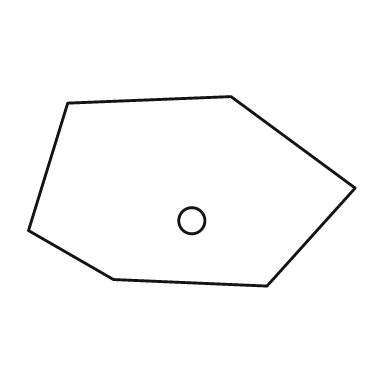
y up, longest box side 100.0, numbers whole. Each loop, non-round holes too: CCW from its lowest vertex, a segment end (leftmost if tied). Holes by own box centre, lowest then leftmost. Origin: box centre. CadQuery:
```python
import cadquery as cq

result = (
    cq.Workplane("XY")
    .moveTo(23.0, -29.0)
    .lineTo(50.0, 1.0)
    .lineTo(12.0, 29.0)
    .lineTo(-38.0, 27.0)
    .lineTo(-50.0, -12.0)
    .lineTo(-24.0, -27.0)
    .close()
    .moveTo(0.0, -9.0)
    .circle(4.0)
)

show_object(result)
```